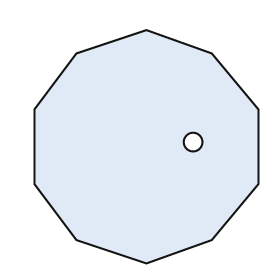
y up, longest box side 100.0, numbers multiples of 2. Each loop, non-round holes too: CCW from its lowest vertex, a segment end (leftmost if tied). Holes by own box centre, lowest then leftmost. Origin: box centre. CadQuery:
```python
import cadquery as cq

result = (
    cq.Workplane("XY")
    .moveTo(0.0, -50.0)
    .lineTo(28.0, -40.0)
    .lineTo(48.0, -16.0)
    .lineTo(48.0, 16.0)
    .lineTo(28.0, 40.0)
    .lineTo(0.0, 50.0)
    .lineTo(-30.0, 40.0)
    .lineTo(-48.0, 16.0)
    .lineTo(-48.0, -16.0)
    .lineTo(-30.0, -40.0)
    .close()
    .moveTo(20.0, 2.0)
    .circle(4.0)
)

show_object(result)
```